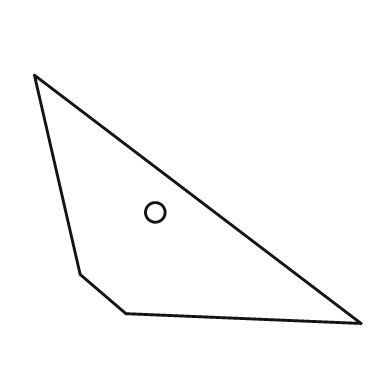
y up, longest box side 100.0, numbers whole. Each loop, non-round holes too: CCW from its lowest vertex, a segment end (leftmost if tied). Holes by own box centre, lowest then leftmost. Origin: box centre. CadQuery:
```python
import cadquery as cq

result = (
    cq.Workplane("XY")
    .moveTo(50.0, -38.0)
    .lineTo(-50.0, 38.0)
    .lineTo(-36.0, -23.0)
    .lineTo(-22.0, -35.0)
    .close()
    .moveTo(-13.0, -4.0)
    .circle(3.0)
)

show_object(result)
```